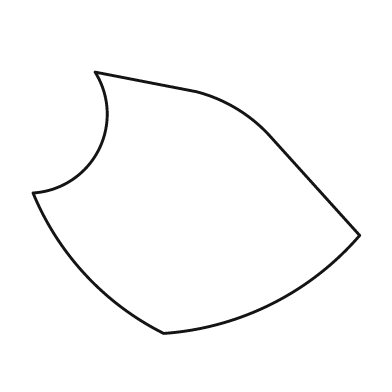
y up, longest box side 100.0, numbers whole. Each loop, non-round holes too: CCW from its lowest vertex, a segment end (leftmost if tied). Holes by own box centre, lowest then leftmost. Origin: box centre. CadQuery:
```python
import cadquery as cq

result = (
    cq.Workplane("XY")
    .moveTo(-10.0, -40.0)
    .threePointArc((23.0, -31.0), (50.0, -10.0))
    .lineTo(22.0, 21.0)
    .threePointArc((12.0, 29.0), (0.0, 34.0))
    .lineTo(-31.0, 40.0)
    .threePointArc((-30.0, 16.0), (-50.0, 3.0))
    .threePointArc((-34.0, -22.0), (-10.0, -40.0))
    .close()
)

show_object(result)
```